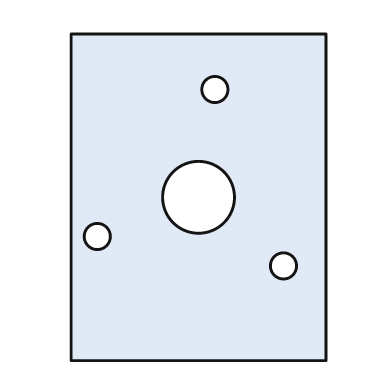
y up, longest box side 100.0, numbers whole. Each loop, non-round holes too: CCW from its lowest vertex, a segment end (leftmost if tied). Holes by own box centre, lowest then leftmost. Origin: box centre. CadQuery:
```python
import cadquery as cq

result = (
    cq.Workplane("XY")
    .moveTo(-39.0, -50.0)
    .lineTo(39.0, -50.0)
    .lineTo(39.0, 50.0)
    .lineTo(-39.0, 50.0)
    .close()
    .moveTo(26.0, -21.0)
    .circle(4.0)
    .moveTo(-31.0, -12.0)
    .circle(4.0)
    .moveTo(0.0, 0.0)
    .circle(11.0)
    .moveTo(5.0, 33.0)
    .circle(4.0)
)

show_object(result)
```